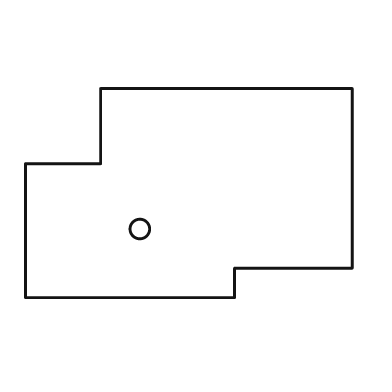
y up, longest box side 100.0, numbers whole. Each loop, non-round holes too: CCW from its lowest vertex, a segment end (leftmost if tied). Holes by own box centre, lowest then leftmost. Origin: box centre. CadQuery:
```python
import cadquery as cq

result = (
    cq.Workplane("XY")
    .moveTo(-50.0, -32.0)
    .lineTo(14.0, -32.0)
    .lineTo(14.0, -23.0)
    .lineTo(50.0, -23.0)
    .lineTo(50.0, 32.0)
    .lineTo(-27.0, 32.0)
    .lineTo(-27.0, 9.0)
    .lineTo(-50.0, 9.0)
    .close()
    .moveTo(-15.0, -11.0)
    .circle(3.0)
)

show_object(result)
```